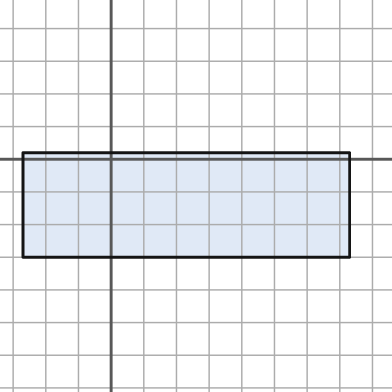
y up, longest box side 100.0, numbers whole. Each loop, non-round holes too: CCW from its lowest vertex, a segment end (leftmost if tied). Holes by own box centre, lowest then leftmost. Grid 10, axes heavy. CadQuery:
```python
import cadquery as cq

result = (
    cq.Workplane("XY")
    .moveTo(-27.0, -30.0)
    .lineTo(73.0, -30.0)
    .lineTo(73.0, 2.0)
    .lineTo(-27.0, 2.0)
    .close()
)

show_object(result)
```